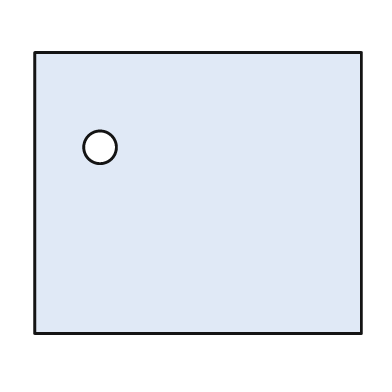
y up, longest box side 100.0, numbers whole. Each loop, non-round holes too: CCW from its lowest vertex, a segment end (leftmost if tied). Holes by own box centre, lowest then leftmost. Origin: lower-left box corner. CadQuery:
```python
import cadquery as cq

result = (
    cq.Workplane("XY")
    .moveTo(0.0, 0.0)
    .lineTo(100.0, 0.0)
    .lineTo(100.0, 86.0)
    .lineTo(0.0, 86.0)
    .close()
    .moveTo(20.0, 57.0)
    .circle(5.0)
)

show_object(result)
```